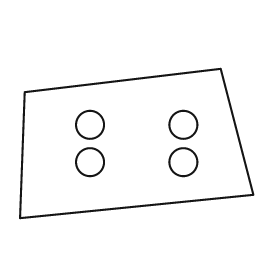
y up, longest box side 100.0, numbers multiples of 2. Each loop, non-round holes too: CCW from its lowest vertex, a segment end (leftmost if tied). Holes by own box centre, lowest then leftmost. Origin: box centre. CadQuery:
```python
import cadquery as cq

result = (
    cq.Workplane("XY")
    .moveTo(-50.0, -32.0)
    .lineTo(50.0, -22.0)
    .lineTo(36.0, 32.0)
    .lineTo(-48.0, 22.0)
    .close()
    .moveTo(-20.0, -8.0)
    .circle(6.0)
    .moveTo(20.0, -8.0)
    .circle(6.0)
    .moveTo(-20.0, 8.0)
    .circle(6.0)
    .moveTo(20.0, 8.0)
    .circle(6.0)
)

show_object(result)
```